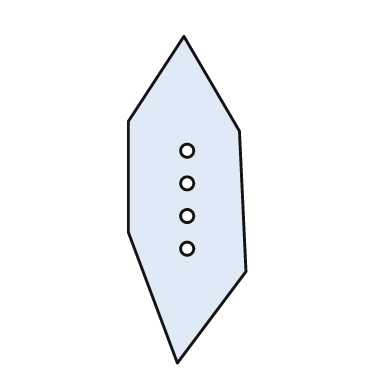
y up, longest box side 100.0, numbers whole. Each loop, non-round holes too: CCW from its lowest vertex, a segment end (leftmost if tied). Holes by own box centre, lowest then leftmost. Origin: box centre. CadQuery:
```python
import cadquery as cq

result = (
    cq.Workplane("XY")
    .moveTo(-3.0, -50.0)
    .lineTo(18.0, -22.0)
    .lineTo(16.0, 21.0)
    .lineTo(-1.0, 50.0)
    .lineTo(-18.0, 24.0)
    .lineTo(-18.0, -10.0)
    .close()
    .moveTo(0.0, -15.0)
    .circle(2.0)
    .moveTo(0.0, -5.0)
    .circle(2.0)
    .moveTo(0.0, 5.0)
    .circle(2.0)
    .moveTo(0.0, 15.0)
    .circle(2.0)
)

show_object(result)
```